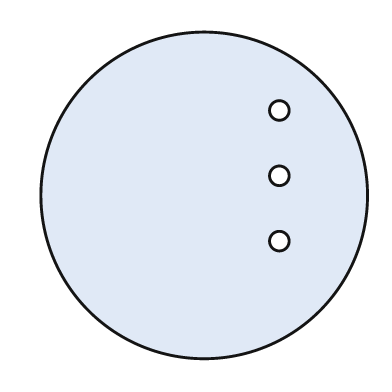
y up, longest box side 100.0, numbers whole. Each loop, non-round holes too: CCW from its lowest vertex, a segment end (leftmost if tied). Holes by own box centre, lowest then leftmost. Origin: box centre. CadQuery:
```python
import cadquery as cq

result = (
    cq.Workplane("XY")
    .moveTo(0.0, 0.0)
    .circle(50.0)
    .moveTo(23.0, -14.0)
    .circle(3.0)
    .moveTo(23.0, 6.0)
    .circle(3.0)
    .moveTo(23.0, 26.0)
    .circle(3.0)
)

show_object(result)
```